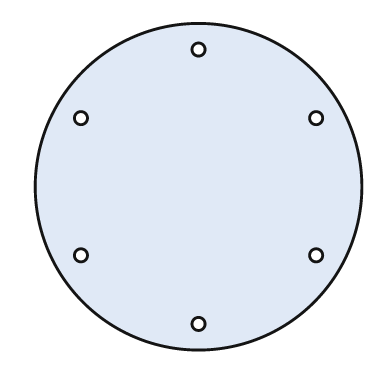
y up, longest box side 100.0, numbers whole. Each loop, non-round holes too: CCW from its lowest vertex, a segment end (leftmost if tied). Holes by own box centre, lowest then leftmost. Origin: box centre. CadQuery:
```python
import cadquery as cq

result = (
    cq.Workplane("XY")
    .moveTo(0.0, 0.0)
    .circle(50.0)
    .moveTo(0.0, -42.0)
    .circle(2.0)
    .moveTo(-36.0, -21.0)
    .circle(2.0)
    .moveTo(36.0, -21.0)
    .circle(2.0)
    .moveTo(-36.0, 21.0)
    .circle(2.0)
    .moveTo(36.0, 21.0)
    .circle(2.0)
    .moveTo(0.0, 42.0)
    .circle(2.0)
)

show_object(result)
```